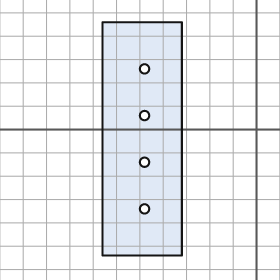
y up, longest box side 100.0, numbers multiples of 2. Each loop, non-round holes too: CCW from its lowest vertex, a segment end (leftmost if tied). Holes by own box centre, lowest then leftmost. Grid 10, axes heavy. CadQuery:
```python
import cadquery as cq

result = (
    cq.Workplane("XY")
    .moveTo(-66.0, -54.0)
    .lineTo(-32.0, -54.0)
    .lineTo(-32.0, 46.0)
    .lineTo(-66.0, 46.0)
    .close()
    .moveTo(-48.0, -34.0)
    .circle(2.0)
    .moveTo(-48.0, -14.0)
    .circle(2.0)
    .moveTo(-48.0, 6.0)
    .circle(2.0)
    .moveTo(-48.0, 26.0)
    .circle(2.0)
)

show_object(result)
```